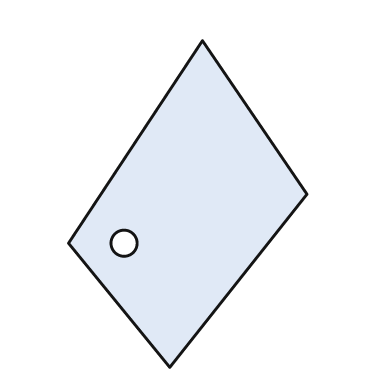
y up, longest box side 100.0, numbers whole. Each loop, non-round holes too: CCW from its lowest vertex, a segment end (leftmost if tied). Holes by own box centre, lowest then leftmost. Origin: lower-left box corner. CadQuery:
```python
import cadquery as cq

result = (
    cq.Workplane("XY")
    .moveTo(31.0, 0.0)
    .lineTo(73.0, 53.0)
    .lineTo(41.0, 100.0)
    .lineTo(0.0, 38.0)
    .close()
    .moveTo(17.0, 38.0)
    .circle(4.0)
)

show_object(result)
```